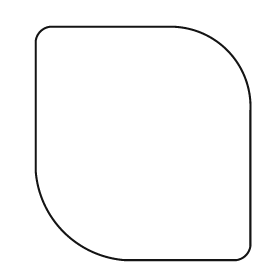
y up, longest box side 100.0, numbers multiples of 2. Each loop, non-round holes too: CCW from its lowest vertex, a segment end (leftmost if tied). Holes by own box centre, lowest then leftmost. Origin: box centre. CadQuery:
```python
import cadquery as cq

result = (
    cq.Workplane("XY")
    .moveTo(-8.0, -50.0)
    .lineTo(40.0, -50.0)
    .threePointArc((44.0, -48.0), (46.0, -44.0))
    .lineTo(46.0, 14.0)
    .threePointArc((36.0, 40.0), (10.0, 50.0))
    .lineTo(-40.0, 50.0)
    .threePointArc((-44.0, 48.0), (-46.0, 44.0))
    .lineTo(-46.0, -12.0)
    .threePointArc((-34.0, -38.0), (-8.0, -50.0))
    .close()
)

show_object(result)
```